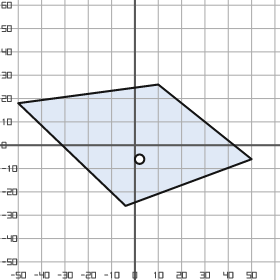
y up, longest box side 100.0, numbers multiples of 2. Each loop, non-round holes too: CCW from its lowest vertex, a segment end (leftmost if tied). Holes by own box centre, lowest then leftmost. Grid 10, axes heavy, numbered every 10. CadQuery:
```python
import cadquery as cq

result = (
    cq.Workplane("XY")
    .moveTo(-4.0, -26.0)
    .lineTo(50.0, -6.0)
    .lineTo(10.0, 26.0)
    .lineTo(-50.0, 18.0)
    .close()
    .moveTo(2.0, -6.0)
    .circle(2.0)
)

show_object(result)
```